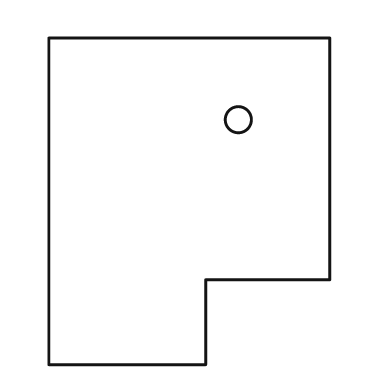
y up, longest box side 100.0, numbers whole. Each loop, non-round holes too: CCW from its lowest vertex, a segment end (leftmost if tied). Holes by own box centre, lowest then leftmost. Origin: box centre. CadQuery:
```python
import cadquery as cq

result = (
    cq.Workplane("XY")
    .moveTo(-43.0, -50.0)
    .lineTo(5.0, -50.0)
    .lineTo(5.0, -24.0)
    .lineTo(43.0, -24.0)
    .lineTo(43.0, 50.0)
    .lineTo(-43.0, 50.0)
    .close()
    .moveTo(15.0, 25.0)
    .circle(4.0)
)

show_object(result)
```